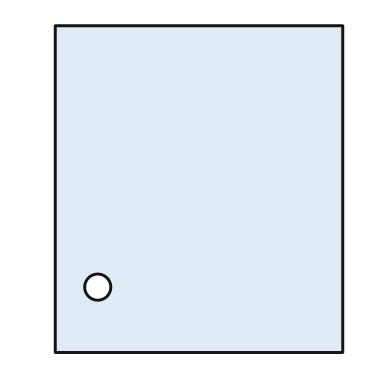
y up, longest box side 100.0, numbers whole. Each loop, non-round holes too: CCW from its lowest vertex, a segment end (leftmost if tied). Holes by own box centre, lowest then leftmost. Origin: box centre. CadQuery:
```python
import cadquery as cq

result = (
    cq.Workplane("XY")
    .moveTo(-44.0, -50.0)
    .lineTo(44.0, -50.0)
    .lineTo(44.0, 50.0)
    .lineTo(-44.0, 50.0)
    .close()
    .moveTo(-31.0, -30.0)
    .circle(4.0)
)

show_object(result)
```